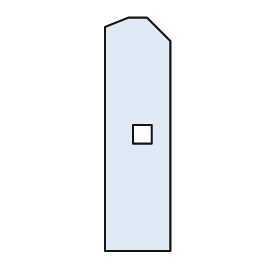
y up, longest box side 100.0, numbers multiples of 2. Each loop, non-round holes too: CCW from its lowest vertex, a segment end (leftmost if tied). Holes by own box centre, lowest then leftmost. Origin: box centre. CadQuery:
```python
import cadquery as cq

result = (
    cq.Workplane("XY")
    .moveTo(-14.0, -50.0)
    .lineTo(14.0, -50.0)
    .lineTo(14.0, 40.0)
    .lineTo(4.0, 50.0)
    .lineTo(-4.0, 50.0)
    .lineTo(-14.0, 46.0)
    .close()
    .moveTo(-2.0, -4.0)
    .lineTo(6.0, -4.0)
    .lineTo(6.0, 4.0)
    .lineTo(-2.0, 4.0)
    .close()
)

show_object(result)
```